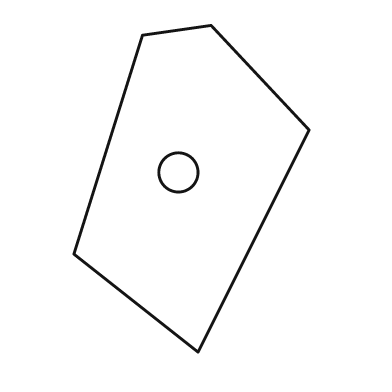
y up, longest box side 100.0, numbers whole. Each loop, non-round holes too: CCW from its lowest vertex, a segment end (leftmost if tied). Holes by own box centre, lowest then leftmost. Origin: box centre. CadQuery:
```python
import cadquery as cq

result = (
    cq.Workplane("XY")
    .moveTo(2.0, -50.0)
    .lineTo(36.0, 18.0)
    .lineTo(6.0, 50.0)
    .lineTo(-15.0, 47.0)
    .lineTo(-36.0, -20.0)
    .close()
    .moveTo(-4.0, 5.0)
    .circle(6.0)
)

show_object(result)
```